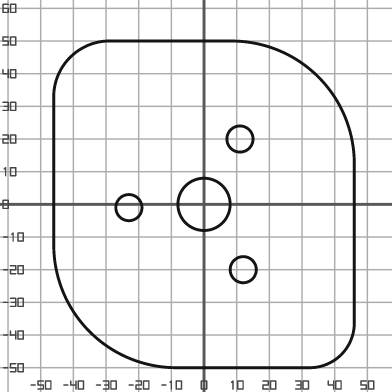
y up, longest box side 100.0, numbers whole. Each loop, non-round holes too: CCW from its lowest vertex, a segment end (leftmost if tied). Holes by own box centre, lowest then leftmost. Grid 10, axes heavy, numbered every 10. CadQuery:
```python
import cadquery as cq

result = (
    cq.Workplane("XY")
    .moveTo(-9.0, -50.0)
    .lineTo(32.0, -50.0)
    .threePointArc((42.0, -46.0), (46.0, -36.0))
    .lineTo(46.0, 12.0)
    .threePointArc((35.0, 39.0), (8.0, 50.0))
    .lineTo(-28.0, 50.0)
    .threePointArc((-41.0, 45.0), (-46.0, 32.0))
    .lineTo(-46.0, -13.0)
    .threePointArc((-35.0, -39.0), (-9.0, -50.0))
    .close()
    .moveTo(12.0, -20.0)
    .circle(4.0)
    .moveTo(-23.0, -1.0)
    .circle(4.0)
    .moveTo(0.0, 0.0)
    .circle(8.0)
    .moveTo(11.0, 20.0)
    .circle(4.0)
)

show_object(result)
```